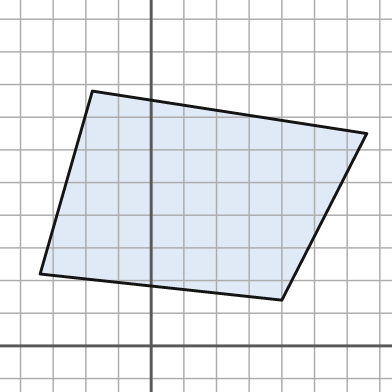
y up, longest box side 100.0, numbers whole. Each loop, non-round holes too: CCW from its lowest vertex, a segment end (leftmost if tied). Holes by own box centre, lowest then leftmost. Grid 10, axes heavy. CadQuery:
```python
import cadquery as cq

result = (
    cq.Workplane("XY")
    .moveTo(40.0, 14.0)
    .lineTo(66.0, 65.0)
    .lineTo(-18.0, 78.0)
    .lineTo(-34.0, 22.0)
    .close()
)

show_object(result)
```